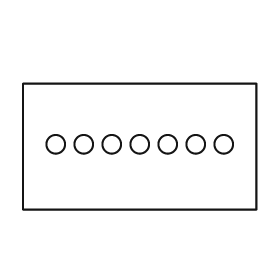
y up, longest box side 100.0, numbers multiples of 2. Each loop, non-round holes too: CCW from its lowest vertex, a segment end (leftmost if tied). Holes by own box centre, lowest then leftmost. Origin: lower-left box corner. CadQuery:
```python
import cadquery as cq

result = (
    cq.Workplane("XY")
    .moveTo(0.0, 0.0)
    .lineTo(100.0, 0.0)
    .lineTo(100.0, 54.0)
    .lineTo(0.0, 54.0)
    .close()
    .moveTo(14.0, 28.0)
    .circle(4.0)
    .moveTo(26.0, 28.0)
    .circle(4.0)
    .moveTo(38.0, 28.0)
    .circle(4.0)
    .moveTo(50.0, 28.0)
    .circle(4.0)
    .moveTo(62.0, 28.0)
    .circle(4.0)
    .moveTo(74.0, 28.0)
    .circle(4.0)
    .moveTo(86.0, 28.0)
    .circle(4.0)
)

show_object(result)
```